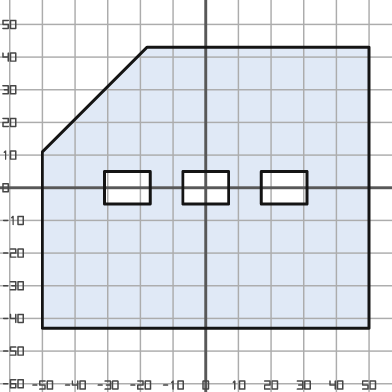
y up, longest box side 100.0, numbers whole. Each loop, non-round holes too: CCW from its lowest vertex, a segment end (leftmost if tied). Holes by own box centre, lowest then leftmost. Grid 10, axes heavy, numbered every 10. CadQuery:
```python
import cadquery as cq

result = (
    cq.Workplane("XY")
    .moveTo(-50.0, -43.0)
    .lineTo(50.0, -43.0)
    .lineTo(50.0, 43.0)
    .lineTo(-18.0, 43.0)
    .lineTo(-50.0, 11.0)
    .close()
    .moveTo(-31.0, -5.0)
    .lineTo(-17.0, -5.0)
    .lineTo(-17.0, 5.0)
    .lineTo(-31.0, 5.0)
    .close()
    .moveTo(-7.0, -5.0)
    .lineTo(7.0, -5.0)
    .lineTo(7.0, 5.0)
    .lineTo(-7.0, 5.0)
    .close()
    .moveTo(17.0, -5.0)
    .lineTo(31.0, -5.0)
    .lineTo(31.0, 5.0)
    .lineTo(17.0, 5.0)
    .close()
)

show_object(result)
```